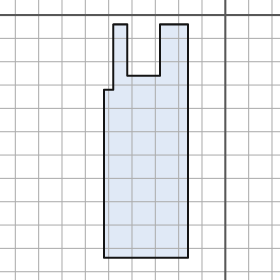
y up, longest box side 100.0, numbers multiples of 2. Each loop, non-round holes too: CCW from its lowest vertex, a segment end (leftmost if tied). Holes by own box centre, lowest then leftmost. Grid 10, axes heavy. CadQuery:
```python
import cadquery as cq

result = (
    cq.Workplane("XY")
    .moveTo(-52.0, -104.0)
    .lineTo(-16.0, -104.0)
    .lineTo(-16.0, -4.0)
    .lineTo(-28.0, -4.0)
    .lineTo(-28.0, -26.0)
    .lineTo(-42.0, -26.0)
    .lineTo(-42.0, -4.0)
    .lineTo(-48.0, -4.0)
    .lineTo(-48.0, -32.0)
    .lineTo(-52.0, -32.0)
    .close()
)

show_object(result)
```